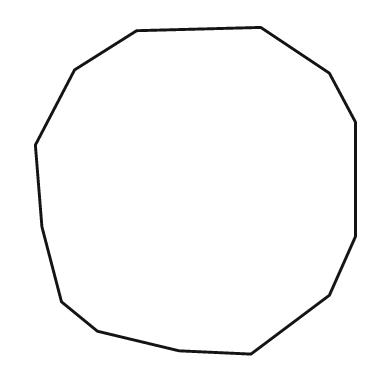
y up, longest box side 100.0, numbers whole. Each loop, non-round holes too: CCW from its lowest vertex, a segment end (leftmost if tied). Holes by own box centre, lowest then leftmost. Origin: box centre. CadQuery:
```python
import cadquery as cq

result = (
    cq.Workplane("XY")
    .moveTo(17.0, -50.0)
    .lineTo(41.0, -32.0)
    .lineTo(49.0, -14.0)
    .lineTo(49.0, 21.0)
    .lineTo(41.0, 36.0)
    .lineTo(20.0, 50.0)
    .lineTo(-18.0, 49.0)
    .lineTo(-37.0, 37.0)
    .lineTo(-49.0, 14.0)
    .lineTo(-47.0, -11.0)
    .lineTo(-41.0, -34.0)
    .lineTo(-30.0, -43.0)
    .lineTo(-5.0, -49.0)
    .close()
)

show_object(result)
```